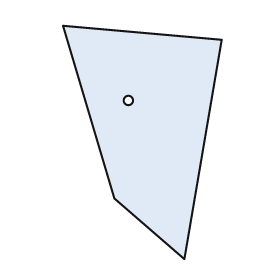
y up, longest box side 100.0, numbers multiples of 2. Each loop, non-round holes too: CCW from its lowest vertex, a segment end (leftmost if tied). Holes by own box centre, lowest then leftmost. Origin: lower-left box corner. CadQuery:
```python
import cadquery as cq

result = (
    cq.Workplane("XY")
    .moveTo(52.0, 0.0)
    .lineTo(68.0, 94.0)
    .lineTo(0.0, 100.0)
    .lineTo(22.0, 26.0)
    .close()
    .moveTo(28.0, 68.0)
    .circle(2.0)
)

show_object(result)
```